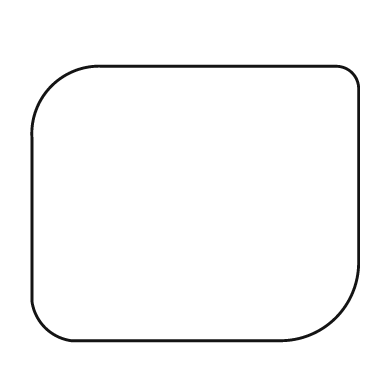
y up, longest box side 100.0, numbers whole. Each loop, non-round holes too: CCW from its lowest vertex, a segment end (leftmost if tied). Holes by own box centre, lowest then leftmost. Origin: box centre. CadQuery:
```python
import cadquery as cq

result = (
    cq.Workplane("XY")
    .moveTo(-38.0, -42.0)
    .lineTo(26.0, -42.0)
    .threePointArc((43.0, -35.0), (50.0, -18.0))
    .lineTo(50.0, 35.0)
    .threePointArc((48.0, 40.0), (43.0, 42.0))
    .lineTo(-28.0, 42.0)
    .threePointArc((-44.0, 36.0), (-50.0, 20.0))
    .lineTo(-50.0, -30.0)
    .threePointArc((-46.0, -38.0), (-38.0, -42.0))
    .close()
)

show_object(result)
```